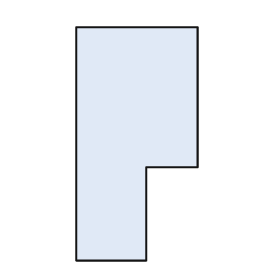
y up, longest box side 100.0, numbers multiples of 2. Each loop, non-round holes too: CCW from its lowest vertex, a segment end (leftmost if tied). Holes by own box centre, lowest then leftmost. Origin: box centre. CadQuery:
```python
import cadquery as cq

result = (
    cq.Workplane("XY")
    .moveTo(-26.0, -50.0)
    .lineTo(4.0, -50.0)
    .lineTo(4.0, -10.0)
    .lineTo(26.0, -10.0)
    .lineTo(26.0, 50.0)
    .lineTo(-26.0, 50.0)
    .close()
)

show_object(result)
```